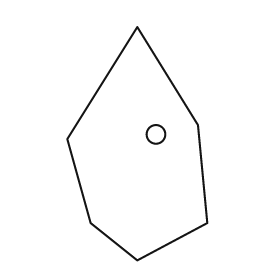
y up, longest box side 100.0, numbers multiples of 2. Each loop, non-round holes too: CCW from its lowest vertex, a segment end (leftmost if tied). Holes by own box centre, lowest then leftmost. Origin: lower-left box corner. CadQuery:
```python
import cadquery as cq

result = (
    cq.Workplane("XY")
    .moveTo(30.0, 0.0)
    .lineTo(60.0, 16.0)
    .lineTo(56.0, 58.0)
    .lineTo(30.0, 100.0)
    .lineTo(0.0, 52.0)
    .lineTo(10.0, 16.0)
    .close()
    .moveTo(38.0, 54.0)
    .circle(4.0)
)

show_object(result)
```